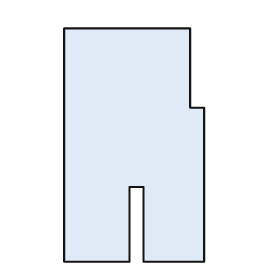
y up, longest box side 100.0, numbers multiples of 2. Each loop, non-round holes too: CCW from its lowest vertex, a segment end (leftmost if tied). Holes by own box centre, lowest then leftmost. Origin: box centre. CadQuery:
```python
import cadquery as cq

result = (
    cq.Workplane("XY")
    .moveTo(-30.0, -50.0)
    .lineTo(-2.0, -50.0)
    .lineTo(-2.0, -18.0)
    .lineTo(4.0, -18.0)
    .lineTo(4.0, -50.0)
    .lineTo(30.0, -50.0)
    .lineTo(30.0, 16.0)
    .lineTo(24.0, 16.0)
    .lineTo(24.0, 50.0)
    .lineTo(-30.0, 50.0)
    .close()
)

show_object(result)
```